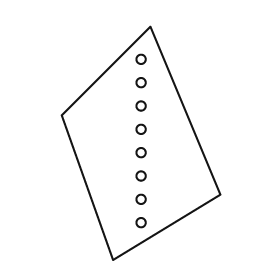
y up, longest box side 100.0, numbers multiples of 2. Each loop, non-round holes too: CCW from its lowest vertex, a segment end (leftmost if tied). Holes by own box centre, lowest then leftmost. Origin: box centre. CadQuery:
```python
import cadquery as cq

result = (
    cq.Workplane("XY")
    .moveTo(-12.0, -50.0)
    .lineTo(34.0, -22.0)
    .lineTo(4.0, 50.0)
    .lineTo(-34.0, 12.0)
    .close()
    .moveTo(0.0, -34.0)
    .circle(2.0)
    .moveTo(0.0, -24.0)
    .circle(2.0)
    .moveTo(0.0, -14.0)
    .circle(2.0)
    .moveTo(0.0, -4.0)
    .circle(2.0)
    .moveTo(0.0, 6.0)
    .circle(2.0)
    .moveTo(0.0, 16.0)
    .circle(2.0)
    .moveTo(0.0, 26.0)
    .circle(2.0)
    .moveTo(0.0, 36.0)
    .circle(2.0)
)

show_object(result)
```